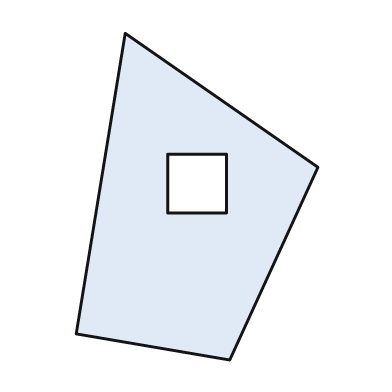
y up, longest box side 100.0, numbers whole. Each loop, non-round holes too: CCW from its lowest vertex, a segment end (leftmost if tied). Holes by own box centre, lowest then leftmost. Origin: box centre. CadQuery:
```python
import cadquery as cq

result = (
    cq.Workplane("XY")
    .moveTo(10.0, -50.0)
    .lineTo(37.0, 9.0)
    .lineTo(-22.0, 50.0)
    .lineTo(-37.0, -42.0)
    .close()
    .moveTo(-9.0, -5.0)
    .lineTo(9.0, -5.0)
    .lineTo(9.0, 13.0)
    .lineTo(-9.0, 13.0)
    .close()
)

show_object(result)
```